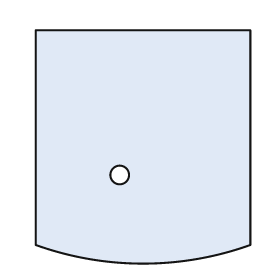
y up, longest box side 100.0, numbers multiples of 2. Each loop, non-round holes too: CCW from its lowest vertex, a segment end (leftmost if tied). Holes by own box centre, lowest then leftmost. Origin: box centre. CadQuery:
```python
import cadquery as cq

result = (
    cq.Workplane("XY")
    .moveTo(-46.0, -42.0)
    .threePointArc((0.0, -50.0), (46.0, -42.0))
    .lineTo(46.0, 50.0)
    .lineTo(-46.0, 50.0)
    .close()
    .moveTo(-10.0, -12.0)
    .circle(4.0)
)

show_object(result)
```